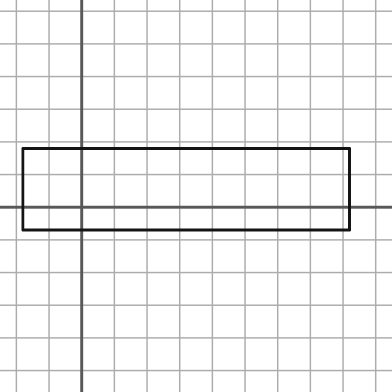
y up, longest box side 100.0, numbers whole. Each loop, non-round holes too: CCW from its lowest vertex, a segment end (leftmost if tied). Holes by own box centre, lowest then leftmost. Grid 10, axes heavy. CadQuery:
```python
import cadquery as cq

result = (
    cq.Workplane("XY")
    .moveTo(-18.0, -7.0)
    .lineTo(82.0, -7.0)
    .lineTo(82.0, 18.0)
    .lineTo(-18.0, 18.0)
    .close()
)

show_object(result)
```